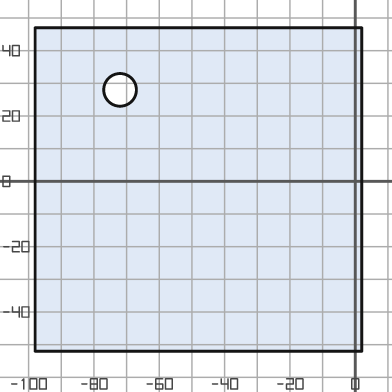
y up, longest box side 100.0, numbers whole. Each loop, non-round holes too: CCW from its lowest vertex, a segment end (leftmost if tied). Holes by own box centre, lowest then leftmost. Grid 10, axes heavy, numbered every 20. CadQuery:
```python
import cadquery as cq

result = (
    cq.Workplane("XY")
    .moveTo(-98.0, -52.0)
    .lineTo(2.0, -52.0)
    .lineTo(2.0, 47.0)
    .lineTo(-98.0, 47.0)
    .close()
    .moveTo(-72.0, 28.0)
    .circle(5.0)
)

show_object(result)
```